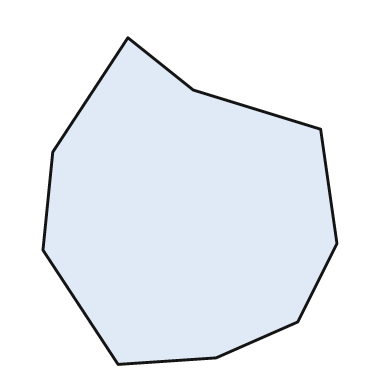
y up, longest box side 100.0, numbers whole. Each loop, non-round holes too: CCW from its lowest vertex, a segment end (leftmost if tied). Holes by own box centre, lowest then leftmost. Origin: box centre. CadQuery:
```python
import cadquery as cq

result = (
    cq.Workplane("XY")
    .moveTo(-22.0, -50.0)
    .lineTo(8.0, -48.0)
    .lineTo(33.0, -37.0)
    .lineTo(45.0, -13.0)
    .lineTo(40.0, 22.0)
    .lineTo(1.0, 34.0)
    .lineTo(-19.0, 50.0)
    .lineTo(-42.0, 15.0)
    .lineTo(-45.0, -15.0)
    .close()
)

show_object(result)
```